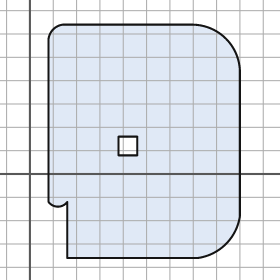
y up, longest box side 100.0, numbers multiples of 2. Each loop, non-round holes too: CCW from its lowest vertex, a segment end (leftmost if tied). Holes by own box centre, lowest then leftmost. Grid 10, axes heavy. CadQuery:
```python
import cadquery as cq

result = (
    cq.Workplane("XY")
    .moveTo(16.0, -36.0)
    .lineTo(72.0, -36.0)
    .threePointArc((84.0, -30.0), (90.0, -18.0))
    .lineTo(90.0, 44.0)
    .threePointArc((84.0, 58.0), (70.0, 64.0))
    .lineTo(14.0, 64.0)
    .threePointArc((10.0, 62.0), (8.0, 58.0))
    .lineTo(8.0, -12.0)
    .threePointArc((12.0, -14.0), (16.0, -12.0))
    .close()
    .moveTo(38.0, 8.0)
    .lineTo(46.0, 8.0)
    .lineTo(46.0, 16.0)
    .lineTo(38.0, 16.0)
    .close()
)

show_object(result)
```